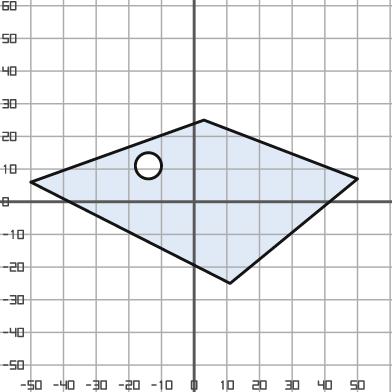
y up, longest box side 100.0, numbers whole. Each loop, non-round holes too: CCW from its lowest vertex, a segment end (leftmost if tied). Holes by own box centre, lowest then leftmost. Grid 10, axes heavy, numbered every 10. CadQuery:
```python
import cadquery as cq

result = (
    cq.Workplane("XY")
    .moveTo(11.0, -25.0)
    .lineTo(50.0, 7.0)
    .lineTo(3.0, 25.0)
    .lineTo(-50.0, 6.0)
    .close()
    .moveTo(-14.0, 11.0)
    .circle(4.0)
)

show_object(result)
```